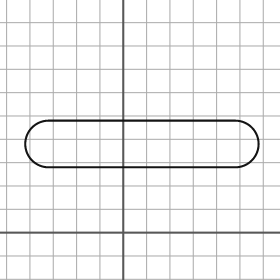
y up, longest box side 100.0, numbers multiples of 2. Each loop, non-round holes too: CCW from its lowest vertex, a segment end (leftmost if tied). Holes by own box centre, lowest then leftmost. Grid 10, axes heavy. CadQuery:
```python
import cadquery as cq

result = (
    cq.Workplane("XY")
    .moveTo(-32.0, 28.0)
    .lineTo(48.0, 28.0)
    .threePointArc((58.0, 38.0), (48.0, 48.0))
    .lineTo(-32.0, 48.0)
    .threePointArc((-42.0, 38.0), (-32.0, 28.0))
    .close()
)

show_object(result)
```